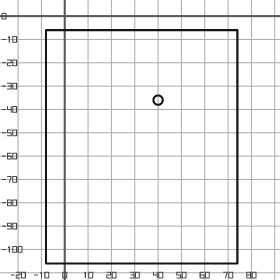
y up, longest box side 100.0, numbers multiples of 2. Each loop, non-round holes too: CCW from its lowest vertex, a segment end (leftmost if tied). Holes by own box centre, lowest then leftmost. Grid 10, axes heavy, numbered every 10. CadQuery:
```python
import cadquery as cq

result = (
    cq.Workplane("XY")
    .moveTo(-8.0, -106.0)
    .lineTo(74.0, -106.0)
    .lineTo(74.0, -6.0)
    .lineTo(-8.0, -6.0)
    .close()
    .moveTo(40.0, -36.0)
    .circle(2.0)
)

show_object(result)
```